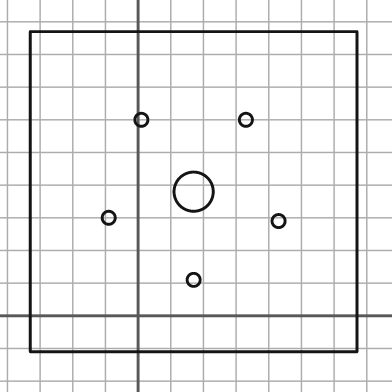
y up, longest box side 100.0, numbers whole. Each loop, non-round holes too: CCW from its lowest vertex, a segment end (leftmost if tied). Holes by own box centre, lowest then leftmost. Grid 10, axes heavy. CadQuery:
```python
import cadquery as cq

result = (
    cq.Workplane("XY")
    .moveTo(-33.0, -11.0)
    .lineTo(67.0, -11.0)
    .lineTo(67.0, 87.0)
    .lineTo(-33.0, 87.0)
    .close()
    .moveTo(17.0, 11.0)
    .circle(2.0)
    .moveTo(43.0, 29.0)
    .circle(2.0)
    .moveTo(-9.0, 30.0)
    .circle(2.0)
    .moveTo(17.0, 38.0)
    .circle(6.0)
    .moveTo(1.0, 60.0)
    .circle(2.0)
    .moveTo(33.0, 60.0)
    .circle(2.0)
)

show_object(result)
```